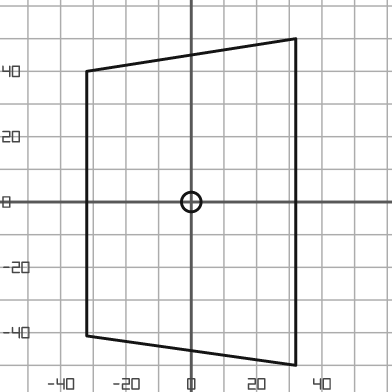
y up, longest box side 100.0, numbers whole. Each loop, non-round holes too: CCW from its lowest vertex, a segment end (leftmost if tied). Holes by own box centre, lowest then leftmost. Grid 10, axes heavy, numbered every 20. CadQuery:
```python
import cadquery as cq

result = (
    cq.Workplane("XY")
    .moveTo(32.0, -50.0)
    .lineTo(32.0, 50.0)
    .lineTo(-32.0, 40.0)
    .lineTo(-32.0, -41.0)
    .close()
    .moveTo(0.0, 0.0)
    .circle(3.0)
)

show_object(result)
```